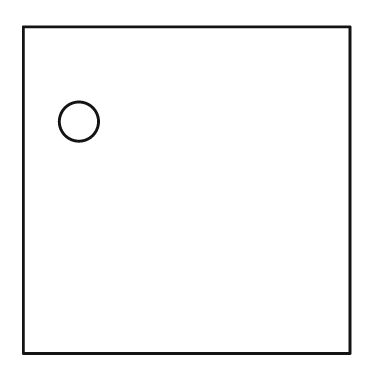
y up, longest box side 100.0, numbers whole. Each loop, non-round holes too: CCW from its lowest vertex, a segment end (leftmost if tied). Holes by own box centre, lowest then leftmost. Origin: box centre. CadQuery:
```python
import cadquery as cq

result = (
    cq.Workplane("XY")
    .moveTo(-50.0, -50.0)
    .lineTo(50.0, -50.0)
    .lineTo(50.0, 50.0)
    .lineTo(-50.0, 50.0)
    .close()
    .moveTo(-33.0, 21.0)
    .circle(6.0)
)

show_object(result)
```